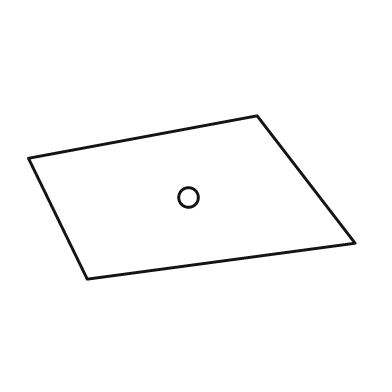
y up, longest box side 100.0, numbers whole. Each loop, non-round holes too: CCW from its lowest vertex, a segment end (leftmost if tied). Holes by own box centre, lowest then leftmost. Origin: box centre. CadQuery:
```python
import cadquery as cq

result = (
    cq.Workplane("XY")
    .moveTo(-32.0, -25.0)
    .lineTo(50.0, -14.0)
    .lineTo(20.0, 25.0)
    .lineTo(-50.0, 12.0)
    .close()
    .moveTo(-1.0, 0.0)
    .circle(3.0)
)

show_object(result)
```